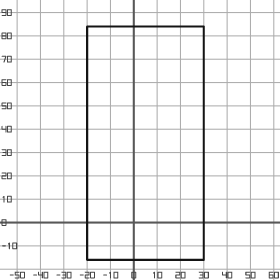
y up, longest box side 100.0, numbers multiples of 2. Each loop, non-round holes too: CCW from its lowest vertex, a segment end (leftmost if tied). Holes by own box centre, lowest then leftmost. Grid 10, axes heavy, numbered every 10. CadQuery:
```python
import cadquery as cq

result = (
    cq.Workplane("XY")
    .moveTo(-20.0, -16.0)
    .lineTo(30.0, -16.0)
    .lineTo(30.0, 84.0)
    .lineTo(-20.0, 84.0)
    .close()
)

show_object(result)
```